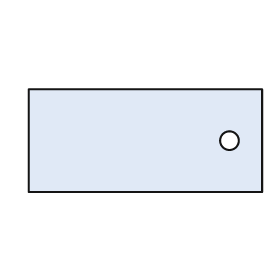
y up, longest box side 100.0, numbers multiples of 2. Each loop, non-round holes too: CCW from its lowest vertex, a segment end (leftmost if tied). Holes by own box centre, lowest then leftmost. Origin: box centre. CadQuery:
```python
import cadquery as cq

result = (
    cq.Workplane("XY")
    .moveTo(-50.0, -22.0)
    .lineTo(50.0, -22.0)
    .lineTo(50.0, 22.0)
    .lineTo(-50.0, 22.0)
    .close()
    .moveTo(36.0, 0.0)
    .circle(4.0)
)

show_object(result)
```